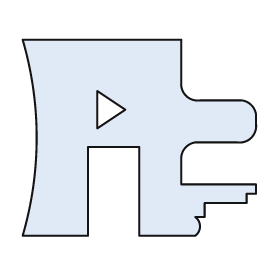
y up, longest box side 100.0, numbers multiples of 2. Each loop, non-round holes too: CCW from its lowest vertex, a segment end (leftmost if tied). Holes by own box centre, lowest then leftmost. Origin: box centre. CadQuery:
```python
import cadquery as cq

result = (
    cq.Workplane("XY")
    .moveTo(-50.0, -42.0)
    .lineTo(-22.0, -42.0)
    .lineTo(-22.0, -4.0)
    .lineTo(0.0, -4.0)
    .lineTo(0.0, -42.0)
    .lineTo(24.0, -42.0)
    .threePointArc((26.0, -38.0), (24.0, -34.0))
    .lineTo(28.0, -34.0)
    .lineTo(28.0, -28.0)
    .lineTo(46.0, -28.0)
    .lineTo(46.0, -24.0)
    .lineTo(50.0, -24.0)
    .lineTo(50.0, -20.0)
    .lineTo(18.0, -20.0)
    .lineTo(18.0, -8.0)
    .threePointArc((20.0, -4.0), (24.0, -2.0))
    .lineTo(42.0, -2.0)
    .threePointArc((48.0, 0.0), (50.0, 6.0))
    .lineTo(50.0, 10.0)
    .threePointArc((48.0, 14.0), (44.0, 16.0))
    .lineTo(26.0, 16.0)
    .threePointArc((20.0, 18.0), (18.0, 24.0))
    .lineTo(18.0, 42.0)
    .lineTo(-50.0, 42.0)
    .threePointArc((-44.0, 0.0), (-50.0, -42.0))
    .close()
    .moveTo(-18.0, 4.0)
    .lineTo(-6.0, 12.0)
    .lineTo(-18.0, 20.0)
    .close()
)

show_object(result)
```